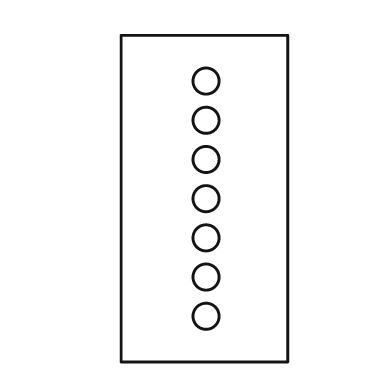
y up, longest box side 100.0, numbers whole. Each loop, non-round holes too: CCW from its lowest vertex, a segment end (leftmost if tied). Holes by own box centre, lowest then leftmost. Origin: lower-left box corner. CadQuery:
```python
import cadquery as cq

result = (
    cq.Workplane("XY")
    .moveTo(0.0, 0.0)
    .lineTo(51.0, 0.0)
    .lineTo(51.0, 100.0)
    .lineTo(0.0, 100.0)
    .close()
    .moveTo(26.0, 14.0)
    .circle(4.0)
    .moveTo(26.0, 26.0)
    .circle(4.0)
    .moveTo(26.0, 38.0)
    .circle(4.0)
    .moveTo(26.0, 50.0)
    .circle(4.0)
    .moveTo(26.0, 62.0)
    .circle(4.0)
    .moveTo(26.0, 74.0)
    .circle(4.0)
    .moveTo(26.0, 86.0)
    .circle(4.0)
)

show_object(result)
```